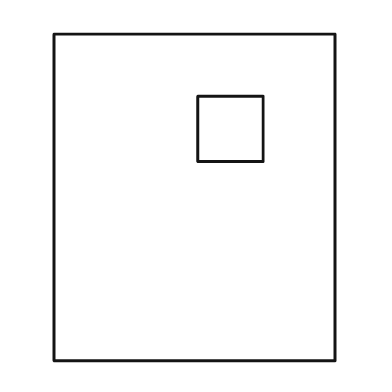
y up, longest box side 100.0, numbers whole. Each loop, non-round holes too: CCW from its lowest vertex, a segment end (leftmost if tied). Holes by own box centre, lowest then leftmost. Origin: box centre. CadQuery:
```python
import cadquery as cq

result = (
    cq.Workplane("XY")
    .moveTo(-43.0, -50.0)
    .lineTo(43.0, -50.0)
    .lineTo(43.0, 50.0)
    .lineTo(-43.0, 50.0)
    .close()
    .moveTo(1.0, 11.0)
    .lineTo(21.0, 11.0)
    .lineTo(21.0, 31.0)
    .lineTo(1.0, 31.0)
    .close()
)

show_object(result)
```